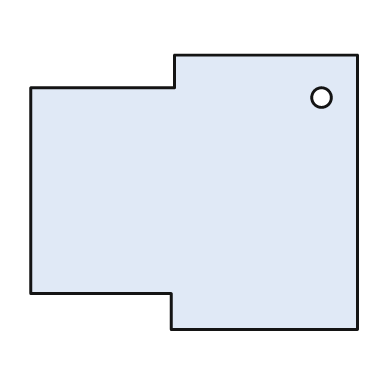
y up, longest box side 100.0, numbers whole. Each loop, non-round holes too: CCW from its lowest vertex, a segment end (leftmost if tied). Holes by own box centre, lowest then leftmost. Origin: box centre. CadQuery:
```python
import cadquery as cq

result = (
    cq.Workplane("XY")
    .moveTo(-7.0, -42.0)
    .lineTo(50.0, -42.0)
    .lineTo(50.0, 42.0)
    .lineTo(-6.0, 42.0)
    .lineTo(-6.0, 32.0)
    .lineTo(-50.0, 32.0)
    .lineTo(-50.0, -31.0)
    .lineTo(-7.0, -31.0)
    .close()
    .moveTo(39.0, 29.0)
    .circle(3.0)
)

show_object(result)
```